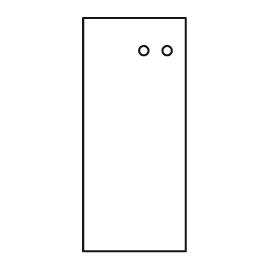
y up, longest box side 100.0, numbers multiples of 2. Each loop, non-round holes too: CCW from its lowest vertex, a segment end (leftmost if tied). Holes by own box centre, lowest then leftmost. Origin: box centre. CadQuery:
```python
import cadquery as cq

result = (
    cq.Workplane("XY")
    .moveTo(-22.0, -50.0)
    .lineTo(22.0, -50.0)
    .lineTo(22.0, 50.0)
    .lineTo(-22.0, 50.0)
    .close()
    .moveTo(4.0, 36.0)
    .circle(2.0)
    .moveTo(14.0, 36.0)
    .circle(2.0)
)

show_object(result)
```